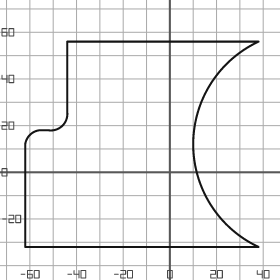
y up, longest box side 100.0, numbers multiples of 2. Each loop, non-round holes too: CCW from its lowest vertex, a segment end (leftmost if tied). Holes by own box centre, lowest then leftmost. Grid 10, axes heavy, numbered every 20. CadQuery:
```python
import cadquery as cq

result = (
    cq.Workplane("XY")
    .moveTo(-62.0, -32.0)
    .lineTo(38.0, -32.0)
    .threePointArc((10.0, 12.0), (38.0, 56.0))
    .lineTo(-44.0, 56.0)
    .lineTo(-44.0, 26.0)
    .threePointArc((-46.0, 20.0), (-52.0, 18.0))
    .lineTo(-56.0, 18.0)
    .threePointArc((-60.0, 16.0), (-62.0, 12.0))
    .close()
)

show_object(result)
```